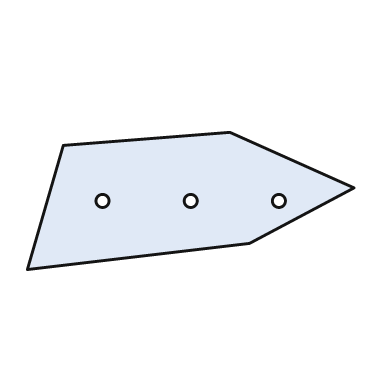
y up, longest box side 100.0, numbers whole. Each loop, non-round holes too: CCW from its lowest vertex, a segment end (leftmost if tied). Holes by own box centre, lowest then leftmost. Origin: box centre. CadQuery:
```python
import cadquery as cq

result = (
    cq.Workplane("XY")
    .moveTo(-50.0, -21.0)
    .lineTo(18.0, -13.0)
    .lineTo(50.0, 4.0)
    .lineTo(12.0, 21.0)
    .lineTo(-39.0, 17.0)
    .close()
    .moveTo(-27.0, 0.0)
    .circle(2.0)
    .moveTo(0.0, 0.0)
    .circle(2.0)
    .moveTo(27.0, 0.0)
    .circle(2.0)
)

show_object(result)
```